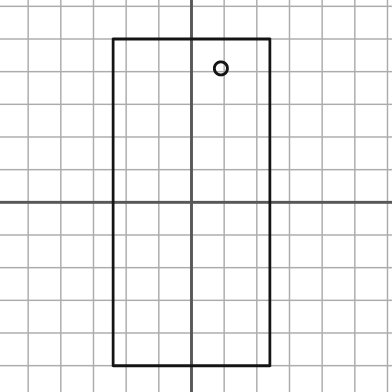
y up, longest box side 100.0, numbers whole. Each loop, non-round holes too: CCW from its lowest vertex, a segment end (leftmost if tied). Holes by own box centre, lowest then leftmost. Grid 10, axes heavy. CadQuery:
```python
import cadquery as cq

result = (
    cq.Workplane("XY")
    .moveTo(-24.0, -50.0)
    .lineTo(24.0, -50.0)
    .lineTo(24.0, 50.0)
    .lineTo(-24.0, 50.0)
    .close()
    .moveTo(9.0, 41.0)
    .circle(2.0)
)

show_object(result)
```